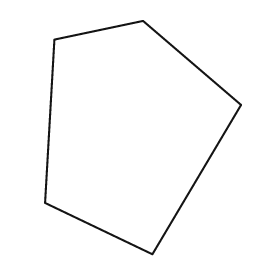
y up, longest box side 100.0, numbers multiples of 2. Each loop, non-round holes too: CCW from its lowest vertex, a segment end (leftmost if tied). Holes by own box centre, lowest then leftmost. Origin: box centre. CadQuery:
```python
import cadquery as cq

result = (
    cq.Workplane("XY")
    .moveTo(4.0, -50.0)
    .lineTo(42.0, 14.0)
    .lineTo(0.0, 50.0)
    .lineTo(-38.0, 42.0)
    .lineTo(-42.0, -28.0)
    .close()
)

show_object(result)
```